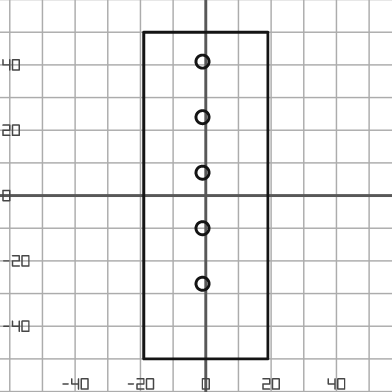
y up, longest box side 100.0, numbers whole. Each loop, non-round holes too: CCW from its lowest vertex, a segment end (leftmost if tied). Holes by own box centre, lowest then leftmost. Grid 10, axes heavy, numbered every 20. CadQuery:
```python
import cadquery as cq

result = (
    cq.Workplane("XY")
    .moveTo(-19.0, -50.0)
    .lineTo(19.0, -50.0)
    .lineTo(19.0, 50.0)
    .lineTo(-19.0, 50.0)
    .close()
    .moveTo(-1.0, -27.0)
    .circle(2.0)
    .moveTo(-1.0, -10.0)
    .circle(2.0)
    .moveTo(-1.0, 7.0)
    .circle(2.0)
    .moveTo(-1.0, 24.0)
    .circle(2.0)
    .moveTo(-1.0, 41.0)
    .circle(2.0)
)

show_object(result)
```